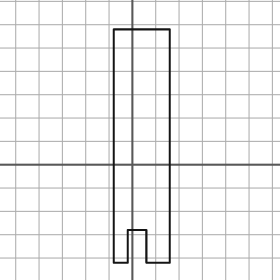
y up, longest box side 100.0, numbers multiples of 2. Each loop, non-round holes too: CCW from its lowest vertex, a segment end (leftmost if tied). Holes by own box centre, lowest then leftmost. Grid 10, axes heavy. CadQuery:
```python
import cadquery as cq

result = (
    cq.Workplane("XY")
    .moveTo(-8.0, -42.0)
    .lineTo(-2.0, -42.0)
    .lineTo(-2.0, -28.0)
    .lineTo(6.0, -28.0)
    .lineTo(6.0, -42.0)
    .lineTo(16.0, -42.0)
    .lineTo(16.0, 58.0)
    .lineTo(-8.0, 58.0)
    .close()
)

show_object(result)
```